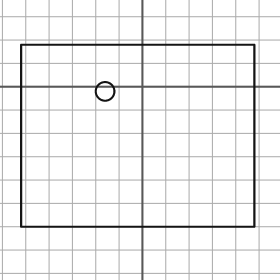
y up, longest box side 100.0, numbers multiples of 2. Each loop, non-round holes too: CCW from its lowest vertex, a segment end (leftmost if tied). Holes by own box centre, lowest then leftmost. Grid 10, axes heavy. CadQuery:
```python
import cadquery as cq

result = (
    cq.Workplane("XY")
    .moveTo(-52.0, -60.0)
    .lineTo(48.0, -60.0)
    .lineTo(48.0, 18.0)
    .lineTo(-52.0, 18.0)
    .close()
    .moveTo(-16.0, -2.0)
    .circle(4.0)
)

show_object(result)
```